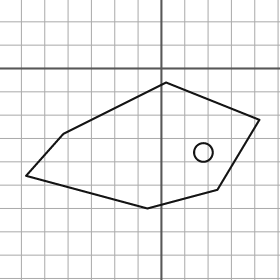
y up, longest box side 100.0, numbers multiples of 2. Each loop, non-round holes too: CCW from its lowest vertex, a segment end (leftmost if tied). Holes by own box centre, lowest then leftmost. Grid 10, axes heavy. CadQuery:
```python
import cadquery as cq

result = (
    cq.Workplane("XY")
    .moveTo(-6.0, -60.0)
    .lineTo(24.0, -52.0)
    .lineTo(42.0, -22.0)
    .lineTo(2.0, -6.0)
    .lineTo(-42.0, -28.0)
    .lineTo(-58.0, -46.0)
    .close()
    .moveTo(18.0, -36.0)
    .circle(4.0)
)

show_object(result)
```